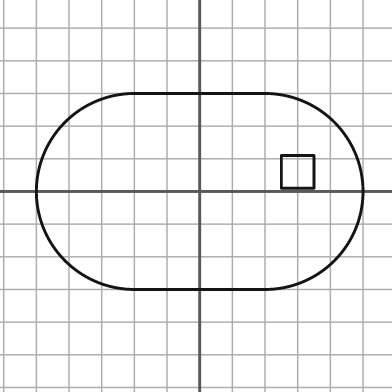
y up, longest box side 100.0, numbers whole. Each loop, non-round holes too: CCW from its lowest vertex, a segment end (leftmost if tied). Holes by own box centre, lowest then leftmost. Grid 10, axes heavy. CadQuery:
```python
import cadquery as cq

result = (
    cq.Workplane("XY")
    .moveTo(-20.0, -30.0)
    .lineTo(20.0, -30.0)
    .threePointArc((50.0, 0.0), (20.0, 30.0))
    .lineTo(-20.0, 30.0)
    .threePointArc((-50.0, 0.0), (-20.0, -30.0))
    .close()
    .moveTo(25.0, 1.0)
    .lineTo(35.0, 1.0)
    .lineTo(35.0, 11.0)
    .lineTo(25.0, 11.0)
    .close()
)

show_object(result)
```